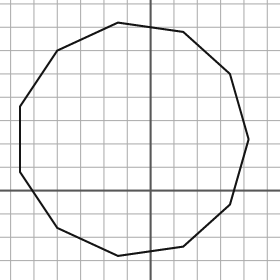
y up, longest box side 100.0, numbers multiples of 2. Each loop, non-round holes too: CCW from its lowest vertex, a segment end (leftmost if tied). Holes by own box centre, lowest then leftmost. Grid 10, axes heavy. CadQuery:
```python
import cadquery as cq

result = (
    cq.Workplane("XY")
    .moveTo(-14.0, -28.0)
    .lineTo(14.0, -24.0)
    .lineTo(34.0, -6.0)
    .lineTo(42.0, 22.0)
    .lineTo(34.0, 50.0)
    .lineTo(14.0, 68.0)
    .lineTo(-14.0, 72.0)
    .lineTo(-40.0, 60.0)
    .lineTo(-56.0, 36.0)
    .lineTo(-56.0, 8.0)
    .lineTo(-40.0, -16.0)
    .close()
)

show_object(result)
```